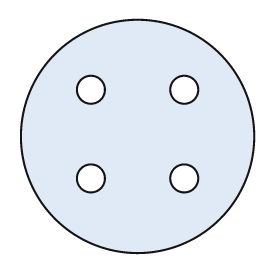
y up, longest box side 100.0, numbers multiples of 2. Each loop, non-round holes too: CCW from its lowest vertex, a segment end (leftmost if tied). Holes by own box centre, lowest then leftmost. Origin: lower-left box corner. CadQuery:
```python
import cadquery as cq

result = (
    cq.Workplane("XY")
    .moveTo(50.0, 50.0)
    .circle(50.0)
    .moveTo(30.0, 32.0)
    .circle(6.0)
    .moveTo(70.0, 32.0)
    .circle(6.0)
    .moveTo(30.0, 70.0)
    .circle(6.0)
    .moveTo(70.0, 70.0)
    .circle(6.0)
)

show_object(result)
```